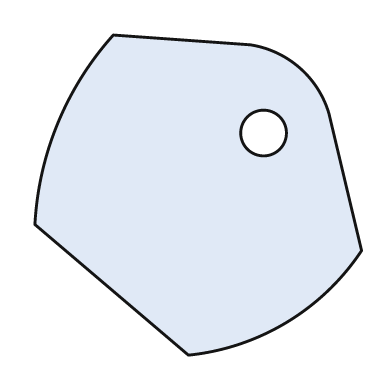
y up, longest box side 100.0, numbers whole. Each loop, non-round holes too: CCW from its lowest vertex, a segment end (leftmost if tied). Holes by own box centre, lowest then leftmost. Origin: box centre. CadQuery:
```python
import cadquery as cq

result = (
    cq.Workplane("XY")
    .moveTo(-3.0, -49.0)
    .threePointArc((27.0, -39.0), (50.0, -17.0))
    .lineTo(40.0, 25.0)
    .threePointArc((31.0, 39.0), (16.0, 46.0))
    .lineTo(-26.0, 49.0)
    .threePointArc((-43.0, 22.0), (-50.0, -9.0))
    .close()
    .moveTo(20.0, 19.0)
    .circle(7.0)
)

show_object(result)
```